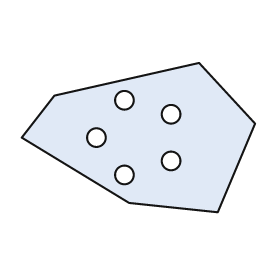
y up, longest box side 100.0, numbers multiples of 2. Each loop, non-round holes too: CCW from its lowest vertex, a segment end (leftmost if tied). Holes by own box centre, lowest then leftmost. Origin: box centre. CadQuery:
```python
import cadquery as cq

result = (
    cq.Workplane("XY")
    .moveTo(34.0, -32.0)
    .lineTo(50.0, 6.0)
    .lineTo(26.0, 32.0)
    .lineTo(-36.0, 18.0)
    .lineTo(-50.0, 0.0)
    .lineTo(-4.0, -28.0)
    .close()
    .moveTo(-6.0, -16.0)
    .circle(4.0)
    .moveTo(14.0, -10.0)
    .circle(4.0)
    .moveTo(-18.0, 0.0)
    .circle(4.0)
    .moveTo(14.0, 10.0)
    .circle(4.0)
    .moveTo(-6.0, 16.0)
    .circle(4.0)
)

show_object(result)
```